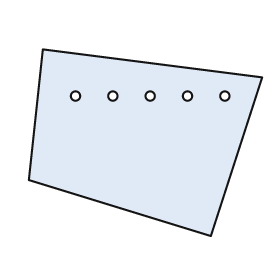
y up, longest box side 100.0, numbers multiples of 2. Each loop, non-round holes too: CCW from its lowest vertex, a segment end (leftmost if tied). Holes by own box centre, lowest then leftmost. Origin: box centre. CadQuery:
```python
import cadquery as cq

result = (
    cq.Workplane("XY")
    .moveTo(28.0, -40.0)
    .lineTo(50.0, 28.0)
    .lineTo(-44.0, 40.0)
    .lineTo(-50.0, -16.0)
    .close()
    .moveTo(-30.0, 20.0)
    .circle(2.0)
    .moveTo(-14.0, 20.0)
    .circle(2.0)
    .moveTo(2.0, 20.0)
    .circle(2.0)
    .moveTo(18.0, 20.0)
    .circle(2.0)
    .moveTo(34.0, 20.0)
    .circle(2.0)
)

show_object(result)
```